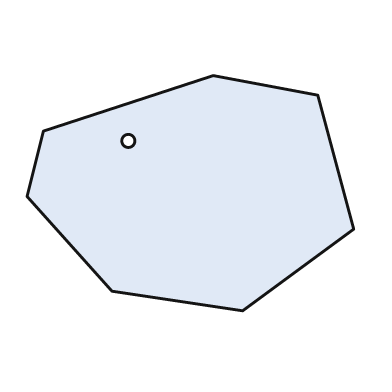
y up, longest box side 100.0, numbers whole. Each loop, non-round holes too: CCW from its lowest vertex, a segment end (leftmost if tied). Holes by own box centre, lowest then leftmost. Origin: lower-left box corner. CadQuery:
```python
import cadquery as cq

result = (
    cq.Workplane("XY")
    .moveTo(66.0, 0.0)
    .lineTo(100.0, 25.0)
    .lineTo(89.0, 66.0)
    .lineTo(57.0, 72.0)
    .lineTo(5.0, 55.0)
    .lineTo(0.0, 35.0)
    .lineTo(26.0, 6.0)
    .close()
    .moveTo(31.0, 52.0)
    .circle(2.0)
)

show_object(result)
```